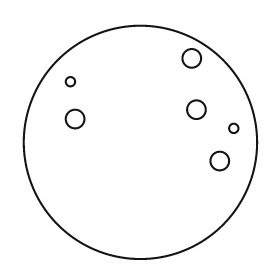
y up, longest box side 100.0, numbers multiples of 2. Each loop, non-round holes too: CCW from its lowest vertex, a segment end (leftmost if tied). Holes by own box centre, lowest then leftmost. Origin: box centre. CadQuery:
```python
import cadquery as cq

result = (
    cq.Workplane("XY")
    .moveTo(0.0, 0.0)
    .circle(50.0)
    .moveTo(34.0, -8.0)
    .circle(4.0)
    .moveTo(40.0, 6.0)
    .circle(2.0)
    .moveTo(-28.0, 10.0)
    .circle(4.0)
    .moveTo(24.0, 14.0)
    .circle(4.0)
    .moveTo(-30.0, 26.0)
    .circle(2.0)
    .moveTo(22.0, 36.0)
    .circle(4.0)
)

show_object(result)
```